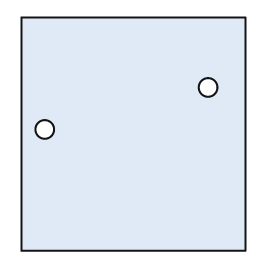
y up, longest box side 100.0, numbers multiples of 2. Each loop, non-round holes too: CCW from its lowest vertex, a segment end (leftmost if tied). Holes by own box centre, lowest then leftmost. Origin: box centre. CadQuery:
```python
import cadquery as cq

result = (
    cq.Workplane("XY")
    .moveTo(-48.0, -50.0)
    .lineTo(48.0, -50.0)
    .lineTo(48.0, 50.0)
    .lineTo(-48.0, 50.0)
    .close()
    .moveTo(-38.0, 2.0)
    .circle(4.0)
    .moveTo(32.0, 20.0)
    .circle(4.0)
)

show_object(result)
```